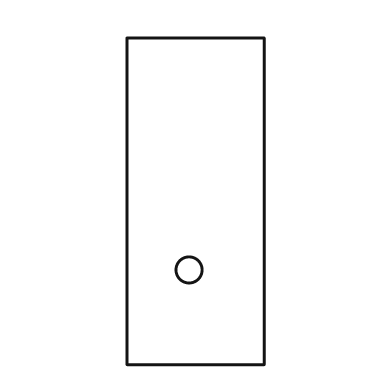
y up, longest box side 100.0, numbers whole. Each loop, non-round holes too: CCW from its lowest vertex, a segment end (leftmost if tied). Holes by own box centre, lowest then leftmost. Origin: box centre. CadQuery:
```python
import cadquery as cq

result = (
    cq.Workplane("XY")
    .moveTo(-21.0, -50.0)
    .lineTo(21.0, -50.0)
    .lineTo(21.0, 50.0)
    .lineTo(-21.0, 50.0)
    .close()
    .moveTo(-2.0, -21.0)
    .circle(4.0)
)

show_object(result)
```